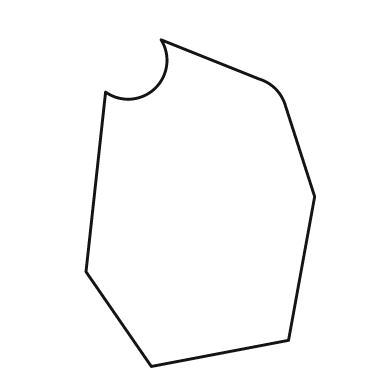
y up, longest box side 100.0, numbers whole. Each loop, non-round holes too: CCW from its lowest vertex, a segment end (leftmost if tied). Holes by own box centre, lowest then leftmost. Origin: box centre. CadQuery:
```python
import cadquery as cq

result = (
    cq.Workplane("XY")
    .moveTo(-15.0, -50.0)
    .lineTo(27.0, -42.0)
    .lineTo(35.0, 2.0)
    .lineTo(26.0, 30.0)
    .threePointArc((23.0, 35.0), (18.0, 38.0))
    .lineTo(-12.0, 50.0)
    .threePointArc((-14.0, 35.0), (-29.0, 34.0))
    .lineTo(-35.0, -21.0)
    .close()
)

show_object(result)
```